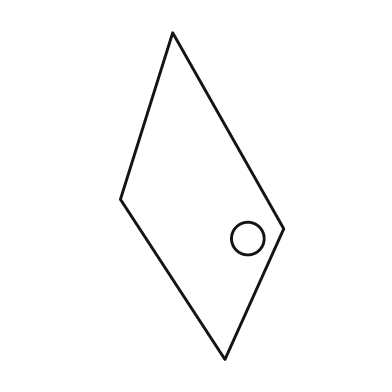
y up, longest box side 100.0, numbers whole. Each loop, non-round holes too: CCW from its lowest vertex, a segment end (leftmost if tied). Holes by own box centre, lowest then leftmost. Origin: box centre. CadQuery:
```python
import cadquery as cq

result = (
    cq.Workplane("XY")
    .moveTo(7.0, -50.0)
    .lineTo(25.0, -10.0)
    .lineTo(-9.0, 50.0)
    .lineTo(-25.0, -1.0)
    .close()
    .moveTo(14.0, -13.0)
    .circle(5.0)
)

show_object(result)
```